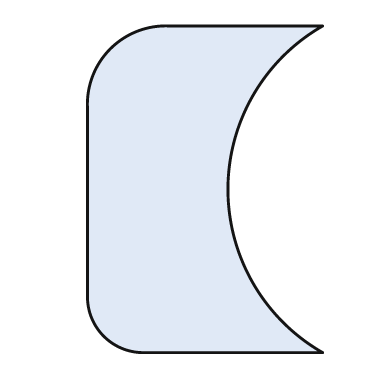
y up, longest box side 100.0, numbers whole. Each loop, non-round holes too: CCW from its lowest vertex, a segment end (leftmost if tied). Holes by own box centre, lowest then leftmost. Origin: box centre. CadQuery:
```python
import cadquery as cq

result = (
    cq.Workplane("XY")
    .moveTo(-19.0, -50.0)
    .lineTo(36.0, -50.0)
    .threePointArc((7.0, 0.0), (36.0, 50.0))
    .lineTo(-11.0, 50.0)
    .threePointArc((-29.0, 43.0), (-36.0, 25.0))
    .lineTo(-36.0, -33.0)
    .threePointArc((-31.0, -45.0), (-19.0, -50.0))
    .close()
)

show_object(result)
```